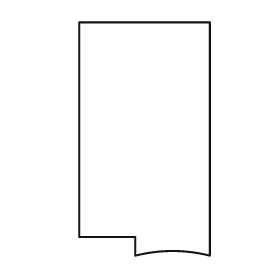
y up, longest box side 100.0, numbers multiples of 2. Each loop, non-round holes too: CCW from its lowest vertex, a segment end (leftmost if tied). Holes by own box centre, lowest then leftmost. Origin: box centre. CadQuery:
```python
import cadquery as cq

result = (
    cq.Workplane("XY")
    .moveTo(-4.0, -50.0)
    .threePointArc((12.0, -48.0), (28.0, -50.0))
    .lineTo(28.0, 50.0)
    .lineTo(-28.0, 50.0)
    .lineTo(-28.0, -42.0)
    .lineTo(-4.0, -42.0)
    .close()
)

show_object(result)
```